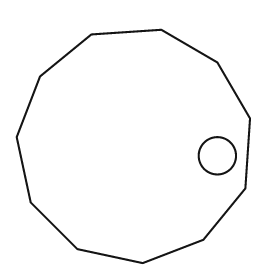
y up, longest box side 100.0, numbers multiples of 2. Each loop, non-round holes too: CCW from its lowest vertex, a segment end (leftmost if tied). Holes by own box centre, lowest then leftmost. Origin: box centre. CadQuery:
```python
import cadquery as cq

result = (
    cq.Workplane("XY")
    .moveTo(4.0, -50.0)
    .lineTo(30.0, -40.0)
    .lineTo(48.0, -18.0)
    .lineTo(50.0, 12.0)
    .lineTo(36.0, 36.0)
    .lineTo(12.0, 50.0)
    .lineTo(-18.0, 48.0)
    .lineTo(-40.0, 30.0)
    .lineTo(-50.0, 4.0)
    .lineTo(-44.0, -24.0)
    .lineTo(-24.0, -44.0)
    .close()
    .moveTo(36.0, -4.0)
    .circle(8.0)
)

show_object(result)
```